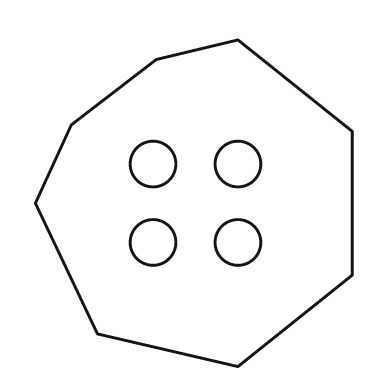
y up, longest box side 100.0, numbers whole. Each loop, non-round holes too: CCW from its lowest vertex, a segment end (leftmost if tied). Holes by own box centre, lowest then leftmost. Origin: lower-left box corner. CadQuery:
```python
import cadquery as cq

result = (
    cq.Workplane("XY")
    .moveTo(62.0, 0.0)
    .lineTo(97.0, 28.0)
    .lineTo(97.0, 72.0)
    .lineTo(62.0, 100.0)
    .lineTo(37.0, 94.0)
    .lineTo(11.0, 74.0)
    .lineTo(0.0, 50.0)
    .lineTo(19.0, 10.0)
    .close()
    .moveTo(36.0, 38.0)
    .circle(7.0)
    .moveTo(62.0, 38.0)
    .circle(7.0)
    .moveTo(36.0, 62.0)
    .circle(7.0)
    .moveTo(62.0, 62.0)
    .circle(7.0)
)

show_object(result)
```